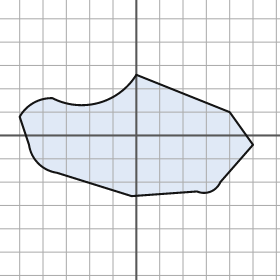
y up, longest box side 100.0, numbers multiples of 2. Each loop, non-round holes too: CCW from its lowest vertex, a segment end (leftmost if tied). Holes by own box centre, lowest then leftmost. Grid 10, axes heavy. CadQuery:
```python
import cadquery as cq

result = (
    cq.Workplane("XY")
    .moveTo(-2.0, -26.0)
    .lineTo(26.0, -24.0)
    .threePointArc((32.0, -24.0), (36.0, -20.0))
    .lineTo(50.0, -4.0)
    .lineTo(40.0, 10.0)
    .lineTo(0.0, 26.0)
    .threePointArc((-16.0, 14.0), (-36.0, 16.0))
    .threePointArc((-44.0, 14.0), (-50.0, 8.0))
    .lineTo(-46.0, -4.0)
    .threePointArc((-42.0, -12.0), (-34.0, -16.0))
    .close()
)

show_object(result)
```